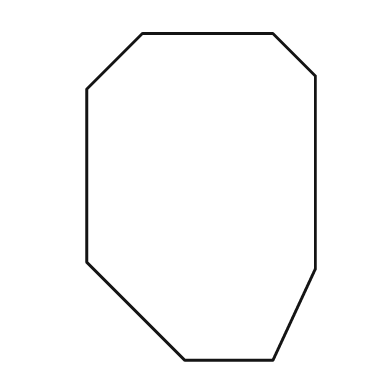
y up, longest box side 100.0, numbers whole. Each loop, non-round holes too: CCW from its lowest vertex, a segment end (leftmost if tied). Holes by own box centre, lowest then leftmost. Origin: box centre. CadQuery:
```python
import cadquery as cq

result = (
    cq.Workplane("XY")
    .moveTo(-5.0, -50.0)
    .lineTo(22.0, -50.0)
    .lineTo(35.0, -22.0)
    .lineTo(35.0, 37.0)
    .lineTo(22.0, 50.0)
    .lineTo(-18.0, 50.0)
    .lineTo(-35.0, 33.0)
    .lineTo(-35.0, -20.0)
    .close()
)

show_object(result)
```